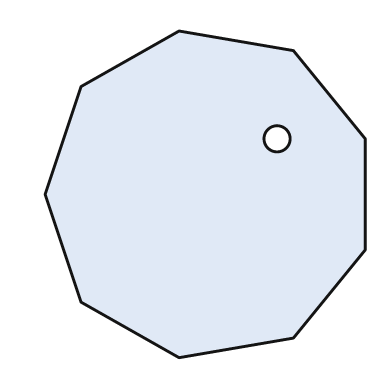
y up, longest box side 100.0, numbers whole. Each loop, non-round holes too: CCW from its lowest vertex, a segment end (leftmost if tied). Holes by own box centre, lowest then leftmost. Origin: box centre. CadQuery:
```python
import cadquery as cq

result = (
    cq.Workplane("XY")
    .moveTo(-8.0, -50.0)
    .lineTo(27.0, -44.0)
    .lineTo(49.0, -17.0)
    .lineTo(49.0, 17.0)
    .lineTo(27.0, 44.0)
    .lineTo(-8.0, 50.0)
    .lineTo(-38.0, 33.0)
    .lineTo(-49.0, 0.0)
    .lineTo(-38.0, -33.0)
    .close()
    .moveTo(22.0, 17.0)
    .circle(4.0)
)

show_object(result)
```